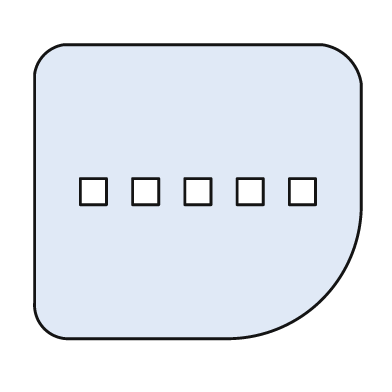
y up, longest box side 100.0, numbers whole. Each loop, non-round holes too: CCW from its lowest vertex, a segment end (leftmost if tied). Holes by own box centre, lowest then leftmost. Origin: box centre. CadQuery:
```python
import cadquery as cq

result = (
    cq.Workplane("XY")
    .moveTo(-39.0, -45.0)
    .lineTo(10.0, -45.0)
    .threePointArc((38.0, -33.0), (50.0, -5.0))
    .lineTo(50.0, 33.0)
    .threePointArc((46.0, 41.0), (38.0, 45.0))
    .lineTo(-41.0, 45.0)
    .threePointArc((-47.0, 42.0), (-50.0, 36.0))
    .lineTo(-50.0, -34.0)
    .threePointArc((-47.0, -42.0), (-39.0, -45.0))
    .close()
    .moveTo(-36.0, -4.0)
    .lineTo(-28.0, -4.0)
    .lineTo(-28.0, 4.0)
    .lineTo(-36.0, 4.0)
    .close()
    .moveTo(-20.0, -4.0)
    .lineTo(-12.0, -4.0)
    .lineTo(-12.0, 4.0)
    .lineTo(-20.0, 4.0)
    .close()
    .moveTo(-4.0, -4.0)
    .lineTo(4.0, -4.0)
    .lineTo(4.0, 4.0)
    .lineTo(-4.0, 4.0)
    .close()
    .moveTo(12.0, -4.0)
    .lineTo(20.0, -4.0)
    .lineTo(20.0, 4.0)
    .lineTo(12.0, 4.0)
    .close()
    .moveTo(28.0, -4.0)
    .lineTo(36.0, -4.0)
    .lineTo(36.0, 4.0)
    .lineTo(28.0, 4.0)
    .close()
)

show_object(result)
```